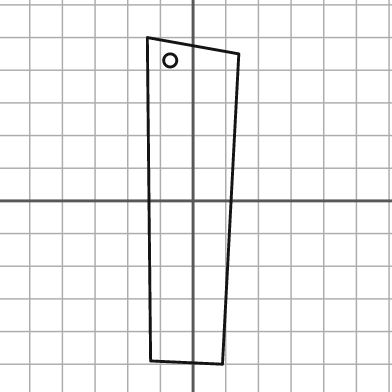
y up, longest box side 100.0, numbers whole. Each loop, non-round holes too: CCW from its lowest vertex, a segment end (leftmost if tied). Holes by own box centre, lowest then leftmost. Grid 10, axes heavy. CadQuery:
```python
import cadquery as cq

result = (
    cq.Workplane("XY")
    .moveTo(9.0, -50.0)
    .lineTo(14.0, 45.0)
    .lineTo(-14.0, 50.0)
    .lineTo(-13.0, -49.0)
    .close()
    .moveTo(-7.0, 43.0)
    .circle(2.0)
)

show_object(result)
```